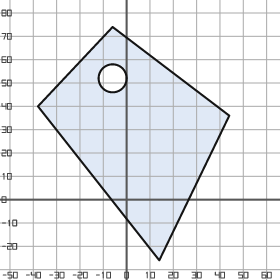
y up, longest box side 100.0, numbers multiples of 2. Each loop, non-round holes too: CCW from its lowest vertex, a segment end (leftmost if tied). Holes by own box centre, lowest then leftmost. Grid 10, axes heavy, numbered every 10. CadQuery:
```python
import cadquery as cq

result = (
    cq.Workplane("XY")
    .moveTo(14.0, -26.0)
    .lineTo(44.0, 36.0)
    .lineTo(-6.0, 74.0)
    .lineTo(-38.0, 40.0)
    .close()
    .moveTo(-6.0, 52.0)
    .circle(6.0)
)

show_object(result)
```